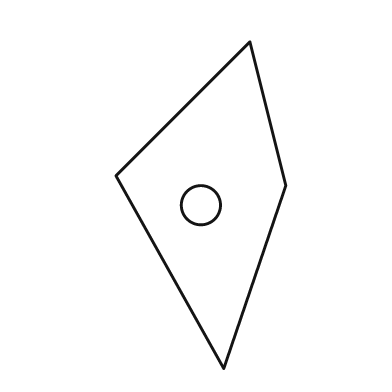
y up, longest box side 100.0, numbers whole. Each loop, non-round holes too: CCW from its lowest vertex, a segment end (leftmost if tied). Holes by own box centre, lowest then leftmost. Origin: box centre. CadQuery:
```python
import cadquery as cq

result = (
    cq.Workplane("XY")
    .moveTo(7.0, -50.0)
    .lineTo(26.0, 6.0)
    .lineTo(15.0, 50.0)
    .lineTo(-26.0, 9.0)
    .close()
    .moveTo(0.0, 0.0)
    .circle(6.0)
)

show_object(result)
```